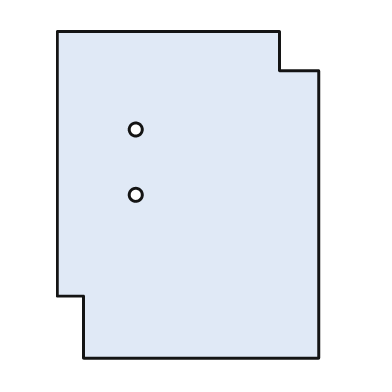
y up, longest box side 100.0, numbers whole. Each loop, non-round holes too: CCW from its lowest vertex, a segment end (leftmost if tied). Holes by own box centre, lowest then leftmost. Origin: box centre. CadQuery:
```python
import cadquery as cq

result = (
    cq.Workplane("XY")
    .moveTo(-32.0, -50.0)
    .lineTo(40.0, -50.0)
    .lineTo(40.0, 38.0)
    .lineTo(28.0, 38.0)
    .lineTo(28.0, 50.0)
    .lineTo(-40.0, 50.0)
    .lineTo(-40.0, -31.0)
    .lineTo(-32.0, -31.0)
    .close()
    .moveTo(-16.0, 0.0)
    .circle(2.0)
    .moveTo(-16.0, 20.0)
    .circle(2.0)
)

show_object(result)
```